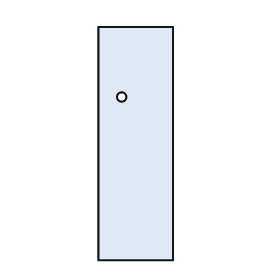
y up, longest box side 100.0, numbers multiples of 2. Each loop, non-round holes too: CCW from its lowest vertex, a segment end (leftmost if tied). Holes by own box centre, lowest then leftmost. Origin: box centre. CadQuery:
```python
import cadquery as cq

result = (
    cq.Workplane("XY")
    .moveTo(-16.0, -50.0)
    .lineTo(16.0, -50.0)
    .lineTo(16.0, 50.0)
    .lineTo(-16.0, 50.0)
    .close()
    .moveTo(-6.0, 20.0)
    .circle(2.0)
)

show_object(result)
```